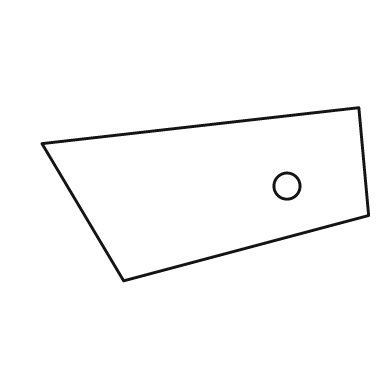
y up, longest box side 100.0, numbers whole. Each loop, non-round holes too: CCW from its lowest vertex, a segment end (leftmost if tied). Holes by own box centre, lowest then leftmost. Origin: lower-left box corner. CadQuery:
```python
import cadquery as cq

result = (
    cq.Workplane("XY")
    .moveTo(25.0, 0.0)
    .lineTo(100.0, 20.0)
    .lineTo(97.0, 53.0)
    .lineTo(0.0, 42.0)
    .close()
    .moveTo(75.0, 29.0)
    .circle(4.0)
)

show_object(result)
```